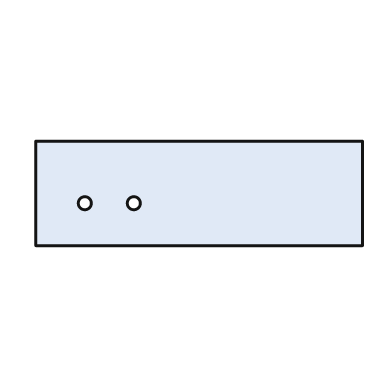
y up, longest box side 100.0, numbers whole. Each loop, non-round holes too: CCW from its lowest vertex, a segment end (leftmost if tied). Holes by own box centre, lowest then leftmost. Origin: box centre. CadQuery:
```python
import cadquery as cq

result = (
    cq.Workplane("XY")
    .moveTo(-50.0, -16.0)
    .lineTo(50.0, -16.0)
    .lineTo(50.0, 16.0)
    .lineTo(-50.0, 16.0)
    .close()
    .moveTo(-35.0, -3.0)
    .circle(2.0)
    .moveTo(-20.0, -3.0)
    .circle(2.0)
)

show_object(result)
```